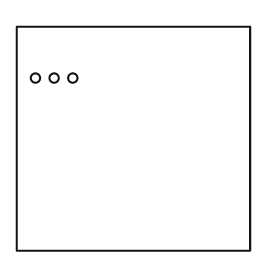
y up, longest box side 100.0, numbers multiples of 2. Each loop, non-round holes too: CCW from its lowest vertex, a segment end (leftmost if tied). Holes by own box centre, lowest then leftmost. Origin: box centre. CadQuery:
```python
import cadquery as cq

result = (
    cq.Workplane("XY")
    .moveTo(-50.0, -48.0)
    .lineTo(50.0, -48.0)
    .lineTo(50.0, 48.0)
    .lineTo(-50.0, 48.0)
    .close()
    .moveTo(-42.0, 26.0)
    .circle(2.0)
    .moveTo(-34.0, 26.0)
    .circle(2.0)
    .moveTo(-26.0, 26.0)
    .circle(2.0)
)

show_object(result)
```